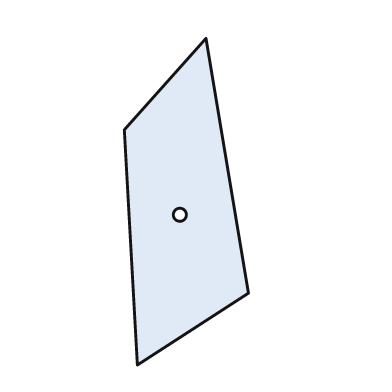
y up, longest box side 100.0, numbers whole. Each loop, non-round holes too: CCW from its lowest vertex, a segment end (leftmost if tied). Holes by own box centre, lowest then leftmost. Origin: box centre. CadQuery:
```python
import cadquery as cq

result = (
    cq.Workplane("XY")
    .moveTo(-15.0, -50.0)
    .lineTo(19.0, -28.0)
    .lineTo(6.0, 50.0)
    .lineTo(-19.0, 22.0)
    .close()
    .moveTo(-2.0, -4.0)
    .circle(2.0)
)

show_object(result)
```